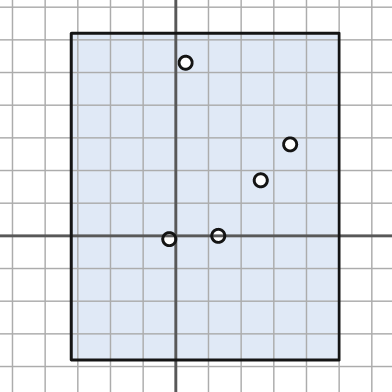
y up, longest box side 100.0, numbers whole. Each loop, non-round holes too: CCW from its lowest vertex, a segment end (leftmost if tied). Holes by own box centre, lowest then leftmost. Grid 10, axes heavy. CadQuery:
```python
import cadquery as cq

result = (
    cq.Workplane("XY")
    .moveTo(-32.0, -38.0)
    .lineTo(50.0, -38.0)
    .lineTo(50.0, 62.0)
    .lineTo(-32.0, 62.0)
    .close()
    .moveTo(-2.0, -1.0)
    .circle(2.0)
    .moveTo(13.0, 0.0)
    .circle(2.0)
    .moveTo(26.0, 17.0)
    .circle(2.0)
    .moveTo(35.0, 28.0)
    .circle(2.0)
    .moveTo(3.0, 53.0)
    .circle(2.0)
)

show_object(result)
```